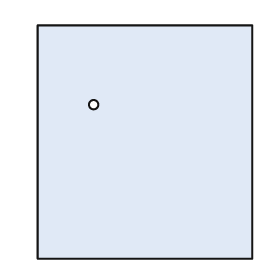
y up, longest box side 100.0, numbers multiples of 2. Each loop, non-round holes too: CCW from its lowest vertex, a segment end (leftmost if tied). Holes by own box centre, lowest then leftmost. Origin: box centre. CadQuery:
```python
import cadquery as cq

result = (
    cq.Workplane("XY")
    .moveTo(-46.0, -50.0)
    .lineTo(46.0, -50.0)
    .lineTo(46.0, 50.0)
    .lineTo(-46.0, 50.0)
    .close()
    .moveTo(-22.0, 16.0)
    .circle(2.0)
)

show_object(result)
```